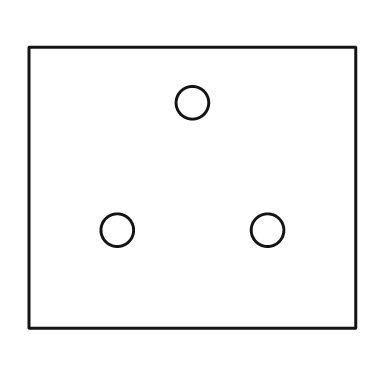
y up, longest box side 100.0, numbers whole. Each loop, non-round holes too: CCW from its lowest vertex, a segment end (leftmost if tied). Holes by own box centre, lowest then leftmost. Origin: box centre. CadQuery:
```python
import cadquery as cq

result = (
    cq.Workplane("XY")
    .moveTo(-50.0, -43.0)
    .lineTo(50.0, -43.0)
    .lineTo(50.0, 43.0)
    .lineTo(-50.0, 43.0)
    .close()
    .moveTo(-23.0, -13.0)
    .circle(5.0)
    .moveTo(23.0, -13.0)
    .circle(5.0)
    .moveTo(0.0, 26.0)
    .circle(5.0)
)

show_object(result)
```